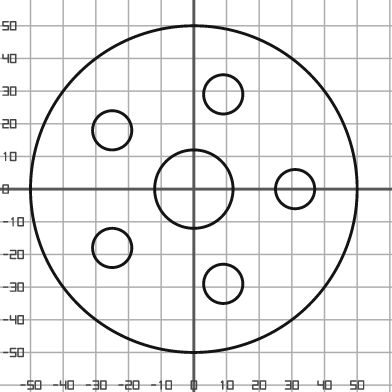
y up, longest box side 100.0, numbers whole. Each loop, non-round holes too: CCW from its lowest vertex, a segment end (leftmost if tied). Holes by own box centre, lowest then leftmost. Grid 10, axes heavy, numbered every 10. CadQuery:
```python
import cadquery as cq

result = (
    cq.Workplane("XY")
    .moveTo(0.0, 0.0)
    .circle(50.0)
    .moveTo(9.0, -29.0)
    .circle(6.0)
    .moveTo(-25.0, -18.0)
    .circle(6.0)
    .moveTo(0.0, 0.0)
    .circle(12.0)
    .moveTo(31.0, 0.0)
    .circle(6.0)
    .moveTo(-25.0, 18.0)
    .circle(6.0)
    .moveTo(9.0, 29.0)
    .circle(6.0)
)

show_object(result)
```